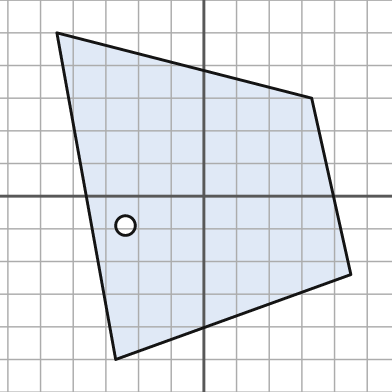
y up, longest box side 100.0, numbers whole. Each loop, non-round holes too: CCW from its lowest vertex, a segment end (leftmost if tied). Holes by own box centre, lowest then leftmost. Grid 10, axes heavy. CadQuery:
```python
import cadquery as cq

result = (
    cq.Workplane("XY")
    .moveTo(-27.0, -50.0)
    .lineTo(45.0, -24.0)
    .lineTo(33.0, 30.0)
    .lineTo(-45.0, 50.0)
    .close()
    .moveTo(-24.0, -9.0)
    .circle(3.0)
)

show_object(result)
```